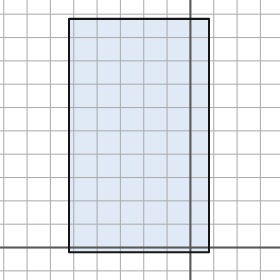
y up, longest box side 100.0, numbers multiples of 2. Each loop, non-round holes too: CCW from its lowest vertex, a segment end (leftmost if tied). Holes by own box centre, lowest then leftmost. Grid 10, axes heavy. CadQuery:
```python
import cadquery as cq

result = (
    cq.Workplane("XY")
    .moveTo(-52.0, -2.0)
    .lineTo(8.0, -2.0)
    .lineTo(8.0, 98.0)
    .lineTo(-52.0, 98.0)
    .close()
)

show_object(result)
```